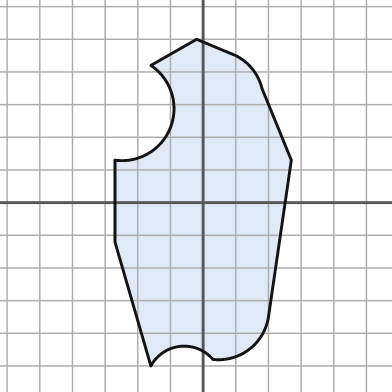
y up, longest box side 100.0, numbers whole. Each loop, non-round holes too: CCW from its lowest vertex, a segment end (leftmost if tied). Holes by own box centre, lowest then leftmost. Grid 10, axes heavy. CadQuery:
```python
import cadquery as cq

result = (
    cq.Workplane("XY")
    .moveTo(-16.0, -50.0)
    .threePointArc((-7.0, -44.0), (3.0, -48.0))
    .threePointArc((14.0, -45.0), (20.0, -35.0))
    .lineTo(27.0, 13.0)
    .lineTo(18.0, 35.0)
    .threePointArc((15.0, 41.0), (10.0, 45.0))
    .lineTo(-2.0, 50.0)
    .lineTo(-16.0, 42.0)
    .threePointArc((-10.0, 23.0), (-27.0, 13.0))
    .lineTo(-27.0, -12.0)
    .close()
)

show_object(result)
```